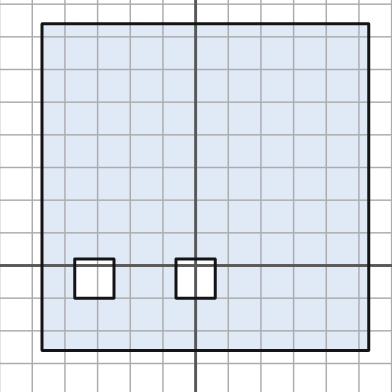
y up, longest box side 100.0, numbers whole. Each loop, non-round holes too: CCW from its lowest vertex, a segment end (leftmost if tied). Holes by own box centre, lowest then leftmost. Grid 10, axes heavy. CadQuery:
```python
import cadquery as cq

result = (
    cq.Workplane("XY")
    .moveTo(-47.0, -26.0)
    .lineTo(53.0, -26.0)
    .lineTo(53.0, 74.0)
    .lineTo(-47.0, 74.0)
    .close()
    .moveTo(-37.0, -10.0)
    .lineTo(-25.0, -10.0)
    .lineTo(-25.0, 2.0)
    .lineTo(-37.0, 2.0)
    .close()
    .moveTo(-6.0, -10.0)
    .lineTo(6.0, -10.0)
    .lineTo(6.0, 2.0)
    .lineTo(-6.0, 2.0)
    .close()
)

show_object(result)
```